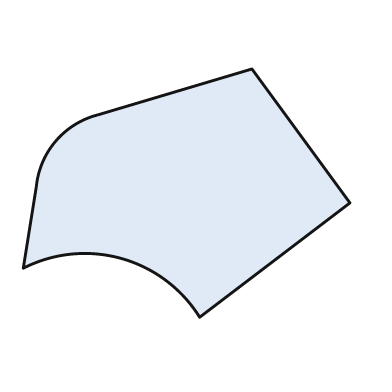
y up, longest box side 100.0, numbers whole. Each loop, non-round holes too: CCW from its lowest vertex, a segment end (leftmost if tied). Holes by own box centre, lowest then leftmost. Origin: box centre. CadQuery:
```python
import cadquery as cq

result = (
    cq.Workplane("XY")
    .moveTo(4.0, -38.0)
    .lineTo(50.0, -3.0)
    .lineTo(20.0, 38.0)
    .lineTo(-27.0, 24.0)
    .threePointArc((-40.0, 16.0), (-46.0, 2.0))
    .lineTo(-50.0, -23.0)
    .threePointArc((-20.0, -20.0), (4.0, -38.0))
    .close()
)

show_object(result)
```